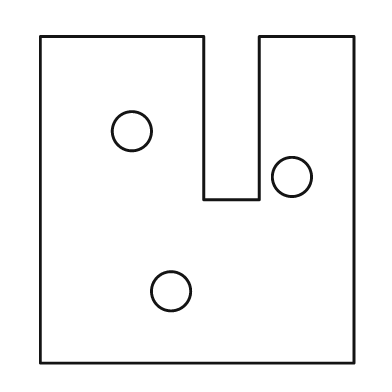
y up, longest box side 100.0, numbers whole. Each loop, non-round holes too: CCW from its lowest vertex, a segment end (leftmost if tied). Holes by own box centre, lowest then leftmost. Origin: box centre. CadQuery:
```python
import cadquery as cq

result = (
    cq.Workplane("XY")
    .moveTo(-48.0, -50.0)
    .lineTo(48.0, -50.0)
    .lineTo(48.0, 50.0)
    .lineTo(19.0, 50.0)
    .lineTo(19.0, 0.0)
    .lineTo(2.0, 0.0)
    .lineTo(2.0, 50.0)
    .lineTo(-48.0, 50.0)
    .close()
    .moveTo(-8.0, -28.0)
    .circle(6.0)
    .moveTo(29.0, 7.0)
    .circle(6.0)
    .moveTo(-20.0, 21.0)
    .circle(6.0)
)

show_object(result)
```